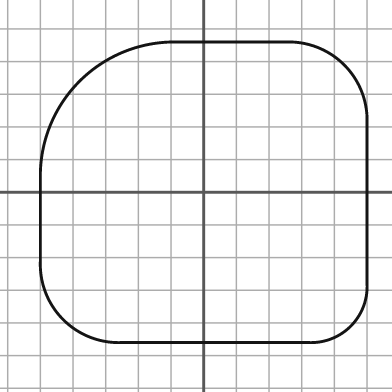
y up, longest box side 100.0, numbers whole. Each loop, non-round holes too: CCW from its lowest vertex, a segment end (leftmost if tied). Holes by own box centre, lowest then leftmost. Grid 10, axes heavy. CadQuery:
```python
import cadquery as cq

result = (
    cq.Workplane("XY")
    .moveTo(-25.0, -46.0)
    .lineTo(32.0, -46.0)
    .threePointArc((45.0, -41.0), (50.0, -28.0))
    .lineTo(50.0, 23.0)
    .threePointArc((43.0, 39.0), (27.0, 46.0))
    .lineTo(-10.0, 46.0)
    .threePointArc((-38.0, 34.0), (-50.0, 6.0))
    .lineTo(-50.0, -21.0)
    .threePointArc((-43.0, -39.0), (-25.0, -46.0))
    .close()
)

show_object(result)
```